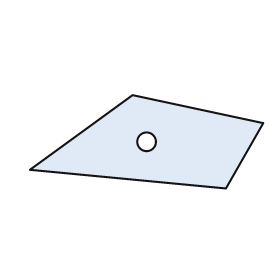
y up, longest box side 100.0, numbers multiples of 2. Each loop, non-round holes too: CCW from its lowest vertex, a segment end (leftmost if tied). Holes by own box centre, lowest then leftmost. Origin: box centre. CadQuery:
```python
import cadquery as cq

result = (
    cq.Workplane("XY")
    .moveTo(34.0, -20.0)
    .lineTo(50.0, 8.0)
    .lineTo(-6.0, 20.0)
    .lineTo(-50.0, -12.0)
    .close()
    .moveTo(0.0, 0.0)
    .circle(4.0)
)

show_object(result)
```